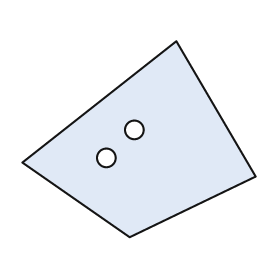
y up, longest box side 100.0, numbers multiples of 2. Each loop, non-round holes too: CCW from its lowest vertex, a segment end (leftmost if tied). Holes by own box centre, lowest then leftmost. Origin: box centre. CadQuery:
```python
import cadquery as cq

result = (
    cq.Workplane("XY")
    .moveTo(-4.0, -42.0)
    .lineTo(50.0, -16.0)
    .lineTo(16.0, 42.0)
    .lineTo(-50.0, -10.0)
    .close()
    .moveTo(-14.0, -8.0)
    .circle(4.0)
    .moveTo(-2.0, 4.0)
    .circle(4.0)
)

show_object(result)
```